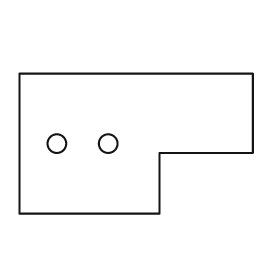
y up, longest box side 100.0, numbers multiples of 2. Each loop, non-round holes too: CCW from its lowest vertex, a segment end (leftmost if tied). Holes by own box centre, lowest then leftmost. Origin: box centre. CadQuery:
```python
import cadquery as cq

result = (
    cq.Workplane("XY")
    .moveTo(-50.0, -30.0)
    .lineTo(10.0, -30.0)
    .lineTo(10.0, -4.0)
    .lineTo(50.0, -4.0)
    .lineTo(50.0, 30.0)
    .lineTo(-50.0, 30.0)
    .close()
    .moveTo(-34.0, 0.0)
    .circle(4.0)
    .moveTo(-12.0, 0.0)
    .circle(4.0)
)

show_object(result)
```